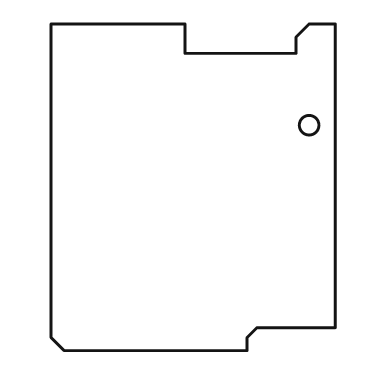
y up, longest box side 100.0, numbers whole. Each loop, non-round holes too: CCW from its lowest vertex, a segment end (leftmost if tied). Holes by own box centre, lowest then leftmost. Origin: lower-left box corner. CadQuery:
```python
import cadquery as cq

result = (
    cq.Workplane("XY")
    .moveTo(4.0, 0.0)
    .lineTo(60.0, 0.0)
    .lineTo(60.0, 4.0)
    .lineTo(63.0, 7.0)
    .lineTo(87.0, 7.0)
    .lineTo(87.0, 100.0)
    .lineTo(79.0, 100.0)
    .lineTo(75.0, 96.0)
    .lineTo(75.0, 91.0)
    .lineTo(41.0, 91.0)
    .lineTo(41.0, 100.0)
    .lineTo(0.0, 100.0)
    .lineTo(0.0, 4.0)
    .close()
    .moveTo(79.0, 69.0)
    .circle(3.0)
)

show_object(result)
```